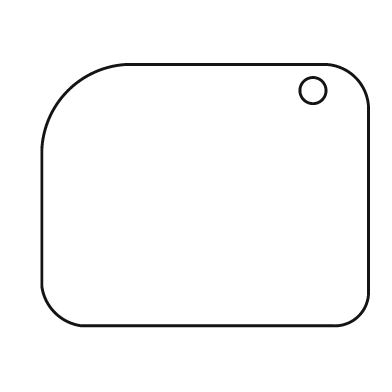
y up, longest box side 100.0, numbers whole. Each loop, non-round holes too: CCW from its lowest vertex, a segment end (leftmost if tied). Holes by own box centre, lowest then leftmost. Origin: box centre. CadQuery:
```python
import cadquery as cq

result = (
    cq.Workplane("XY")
    .moveTo(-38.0, -40.0)
    .lineTo(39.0, -40.0)
    .threePointArc((47.0, -37.0), (50.0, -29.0))
    .lineTo(50.0, 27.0)
    .threePointArc((46.0, 36.0), (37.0, 40.0))
    .lineTo(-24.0, 40.0)
    .threePointArc((-42.0, 32.0), (-50.0, 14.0))
    .lineTo(-50.0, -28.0)
    .threePointArc((-46.0, -36.0), (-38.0, -40.0))
    .close()
    .moveTo(33.0, 32.0)
    .circle(4.0)
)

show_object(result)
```